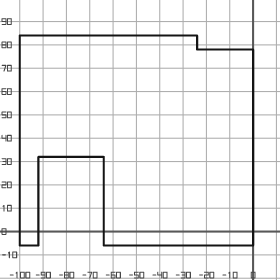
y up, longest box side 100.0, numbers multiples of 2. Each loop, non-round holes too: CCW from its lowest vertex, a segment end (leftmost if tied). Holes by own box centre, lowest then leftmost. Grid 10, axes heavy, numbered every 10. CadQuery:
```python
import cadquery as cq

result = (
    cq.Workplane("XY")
    .moveTo(-100.0, -6.0)
    .lineTo(-92.0, -6.0)
    .lineTo(-92.0, 32.0)
    .lineTo(-64.0, 32.0)
    .lineTo(-64.0, -6.0)
    .lineTo(0.0, -6.0)
    .lineTo(0.0, 78.0)
    .lineTo(-24.0, 78.0)
    .lineTo(-24.0, 84.0)
    .lineTo(-100.0, 84.0)
    .close()
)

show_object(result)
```